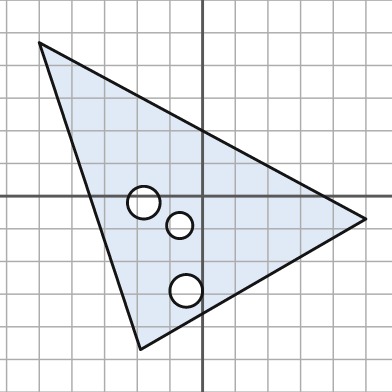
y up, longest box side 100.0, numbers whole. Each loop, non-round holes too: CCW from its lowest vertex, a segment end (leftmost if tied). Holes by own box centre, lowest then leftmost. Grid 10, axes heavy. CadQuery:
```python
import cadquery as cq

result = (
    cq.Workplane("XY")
    .moveTo(-19.0, -47.0)
    .lineTo(50.0, -7.0)
    .lineTo(-50.0, 47.0)
    .close()
    .moveTo(-5.0, -29.0)
    .circle(5.0)
    .moveTo(-7.0, -9.0)
    .circle(4.0)
    .moveTo(-18.0, -2.0)
    .circle(5.0)
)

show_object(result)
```